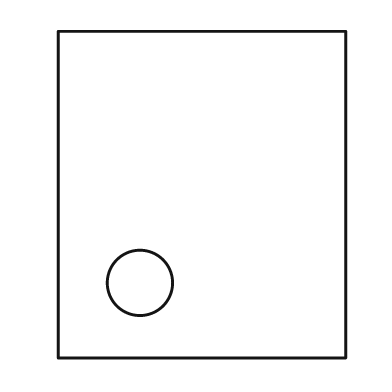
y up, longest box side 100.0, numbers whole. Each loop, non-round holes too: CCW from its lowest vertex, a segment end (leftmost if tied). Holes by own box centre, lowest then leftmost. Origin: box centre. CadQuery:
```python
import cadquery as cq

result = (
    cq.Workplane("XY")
    .moveTo(-44.0, -50.0)
    .lineTo(44.0, -50.0)
    .lineTo(44.0, 50.0)
    .lineTo(-44.0, 50.0)
    .close()
    .moveTo(-19.0, -27.0)
    .circle(10.0)
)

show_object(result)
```